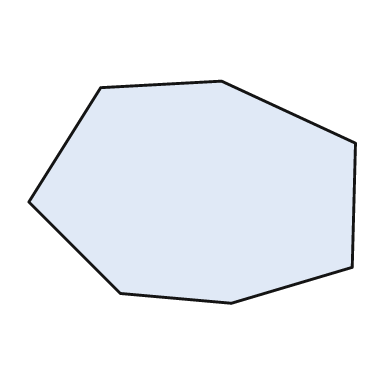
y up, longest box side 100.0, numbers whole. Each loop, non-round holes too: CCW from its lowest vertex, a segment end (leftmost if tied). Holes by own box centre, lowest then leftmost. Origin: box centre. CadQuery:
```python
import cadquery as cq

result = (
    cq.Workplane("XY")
    .moveTo(12.0, -34.0)
    .lineTo(49.0, -23.0)
    .lineTo(50.0, 15.0)
    .lineTo(9.0, 34.0)
    .lineTo(-28.0, 32.0)
    .lineTo(-50.0, -3.0)
    .lineTo(-22.0, -31.0)
    .close()
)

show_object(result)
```